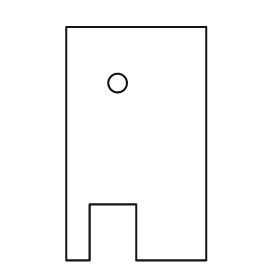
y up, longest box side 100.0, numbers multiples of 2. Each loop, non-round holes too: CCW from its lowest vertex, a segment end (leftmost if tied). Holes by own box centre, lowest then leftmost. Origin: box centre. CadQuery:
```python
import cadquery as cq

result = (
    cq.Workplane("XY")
    .moveTo(-30.0, -50.0)
    .lineTo(-20.0, -50.0)
    .lineTo(-20.0, -26.0)
    .lineTo(0.0, -26.0)
    .lineTo(0.0, -50.0)
    .lineTo(30.0, -50.0)
    .lineTo(30.0, 50.0)
    .lineTo(-30.0, 50.0)
    .close()
    .moveTo(-8.0, 26.0)
    .circle(4.0)
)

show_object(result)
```